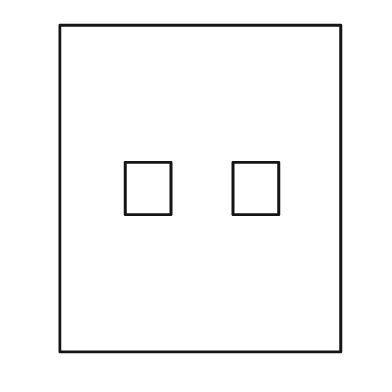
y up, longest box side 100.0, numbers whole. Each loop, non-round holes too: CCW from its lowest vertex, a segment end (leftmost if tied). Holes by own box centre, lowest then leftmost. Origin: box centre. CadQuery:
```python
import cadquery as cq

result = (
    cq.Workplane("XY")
    .moveTo(-43.0, -50.0)
    .lineTo(43.0, -50.0)
    .lineTo(43.0, 50.0)
    .lineTo(-43.0, 50.0)
    .close()
    .moveTo(-23.0, -8.0)
    .lineTo(-9.0, -8.0)
    .lineTo(-9.0, 8.0)
    .lineTo(-23.0, 8.0)
    .close()
    .moveTo(10.0, -8.0)
    .lineTo(24.0, -8.0)
    .lineTo(24.0, 8.0)
    .lineTo(10.0, 8.0)
    .close()
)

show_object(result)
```